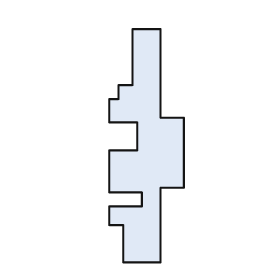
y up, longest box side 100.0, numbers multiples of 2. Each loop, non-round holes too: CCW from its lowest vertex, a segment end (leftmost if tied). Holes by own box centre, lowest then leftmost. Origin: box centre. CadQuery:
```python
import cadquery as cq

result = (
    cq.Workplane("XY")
    .moveTo(-10.0, -50.0)
    .lineTo(6.0, -50.0)
    .lineTo(6.0, -18.0)
    .lineTo(16.0, -18.0)
    .lineTo(16.0, 12.0)
    .lineTo(6.0, 12.0)
    .lineTo(6.0, 50.0)
    .lineTo(-6.0, 50.0)
    .lineTo(-6.0, 26.0)
    .lineTo(-12.0, 26.0)
    .lineTo(-12.0, 20.0)
    .lineTo(-16.0, 20.0)
    .lineTo(-16.0, 10.0)
    .lineTo(-4.0, 10.0)
    .lineTo(-4.0, -2.0)
    .lineTo(-16.0, -2.0)
    .lineTo(-16.0, -20.0)
    .lineTo(-2.0, -20.0)
    .lineTo(-2.0, -26.0)
    .lineTo(-16.0, -26.0)
    .lineTo(-16.0, -34.0)
    .lineTo(-10.0, -34.0)
    .close()
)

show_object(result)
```